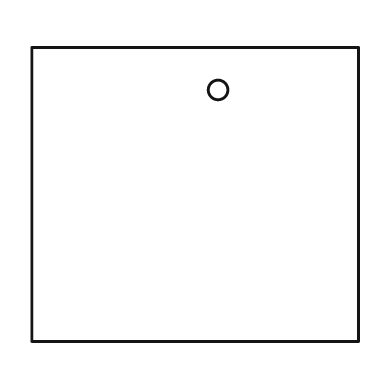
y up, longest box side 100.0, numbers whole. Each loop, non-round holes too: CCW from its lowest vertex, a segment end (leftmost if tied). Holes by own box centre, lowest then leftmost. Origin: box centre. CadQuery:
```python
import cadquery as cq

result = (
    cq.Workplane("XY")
    .moveTo(-50.0, -45.0)
    .lineTo(50.0, -45.0)
    .lineTo(50.0, 45.0)
    .lineTo(-50.0, 45.0)
    .close()
    .moveTo(7.0, 32.0)
    .circle(3.0)
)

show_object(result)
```